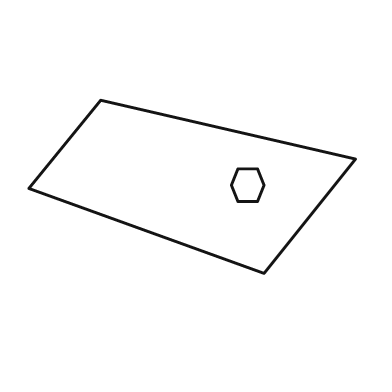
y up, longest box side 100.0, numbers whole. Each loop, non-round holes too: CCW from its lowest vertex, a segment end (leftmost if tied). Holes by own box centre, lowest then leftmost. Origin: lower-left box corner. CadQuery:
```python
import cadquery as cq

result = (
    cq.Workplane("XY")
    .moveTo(72.0, 0.0)
    .lineTo(100.0, 35.0)
    .lineTo(22.0, 53.0)
    .lineTo(0.0, 26.0)
    .close()
    .moveTo(64.0, 22.0)
    .lineTo(70.0, 22.0)
    .lineTo(72.0, 27.0)
    .lineTo(70.0, 32.0)
    .lineTo(64.0, 32.0)
    .lineTo(62.0, 27.0)
    .close()
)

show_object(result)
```